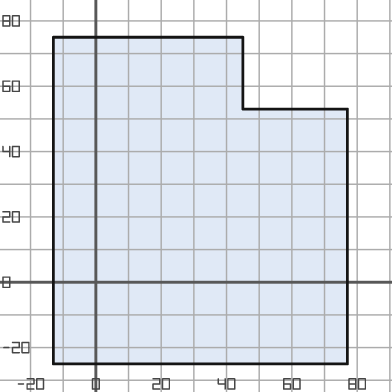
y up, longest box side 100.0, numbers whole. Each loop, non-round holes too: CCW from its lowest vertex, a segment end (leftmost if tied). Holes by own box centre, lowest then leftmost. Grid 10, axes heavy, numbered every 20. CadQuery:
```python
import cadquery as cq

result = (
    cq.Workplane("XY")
    .moveTo(-13.0, -25.0)
    .lineTo(77.0, -25.0)
    .lineTo(77.0, 53.0)
    .lineTo(45.0, 53.0)
    .lineTo(45.0, 75.0)
    .lineTo(-13.0, 75.0)
    .close()
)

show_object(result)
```